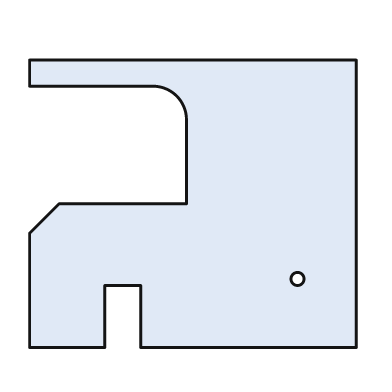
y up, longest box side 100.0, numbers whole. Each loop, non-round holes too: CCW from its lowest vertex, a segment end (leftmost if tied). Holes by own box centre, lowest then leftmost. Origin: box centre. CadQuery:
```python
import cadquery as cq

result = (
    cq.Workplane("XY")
    .moveTo(-50.0, -44.0)
    .lineTo(-27.0, -44.0)
    .lineTo(-27.0, -25.0)
    .lineTo(-16.0, -25.0)
    .lineTo(-16.0, -44.0)
    .lineTo(50.0, -44.0)
    .lineTo(50.0, 44.0)
    .lineTo(-50.0, 44.0)
    .lineTo(-50.0, 36.0)
    .lineTo(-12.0, 36.0)
    .threePointArc((-5.0, 33.0), (-2.0, 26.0))
    .lineTo(-2.0, 0.0)
    .lineTo(-41.0, 0.0)
    .lineTo(-50.0, -9.0)
    .close()
    .moveTo(32.0, -23.0)
    .circle(2.0)
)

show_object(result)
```